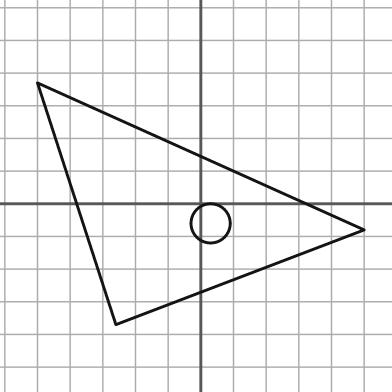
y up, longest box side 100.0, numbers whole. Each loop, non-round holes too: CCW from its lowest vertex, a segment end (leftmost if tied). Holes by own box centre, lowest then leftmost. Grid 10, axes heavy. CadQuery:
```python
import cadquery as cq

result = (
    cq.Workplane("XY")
    .moveTo(-26.0, -37.0)
    .lineTo(50.0, -8.0)
    .lineTo(-50.0, 37.0)
    .close()
    .moveTo(3.0, -6.0)
    .circle(6.0)
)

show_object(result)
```